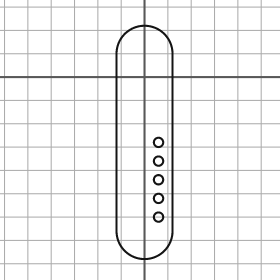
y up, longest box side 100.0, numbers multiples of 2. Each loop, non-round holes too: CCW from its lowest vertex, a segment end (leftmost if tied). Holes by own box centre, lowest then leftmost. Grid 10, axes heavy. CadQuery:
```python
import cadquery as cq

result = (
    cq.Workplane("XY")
    .moveTo(-12.0, -66.0)
    .threePointArc((0.0, -78.0), (12.0, -66.0))
    .lineTo(12.0, 10.0)
    .threePointArc((0.0, 22.0), (-12.0, 10.0))
    .close()
    .moveTo(6.0, -60.0)
    .circle(2.0)
    .moveTo(6.0, -52.0)
    .circle(2.0)
    .moveTo(6.0, -44.0)
    .circle(2.0)
    .moveTo(6.0, -36.0)
    .circle(2.0)
    .moveTo(6.0, -28.0)
    .circle(2.0)
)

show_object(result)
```